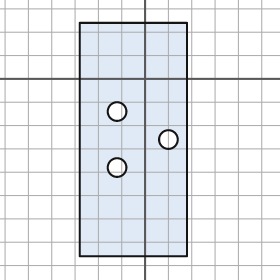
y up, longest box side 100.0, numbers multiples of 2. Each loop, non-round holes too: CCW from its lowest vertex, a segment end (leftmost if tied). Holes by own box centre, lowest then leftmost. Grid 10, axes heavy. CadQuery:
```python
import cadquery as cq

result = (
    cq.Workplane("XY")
    .moveTo(-28.0, -76.0)
    .lineTo(18.0, -76.0)
    .lineTo(18.0, 24.0)
    .lineTo(-28.0, 24.0)
    .close()
    .moveTo(-12.0, -38.0)
    .circle(4.0)
    .moveTo(10.0, -26.0)
    .circle(4.0)
    .moveTo(-12.0, -14.0)
    .circle(4.0)
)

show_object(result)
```